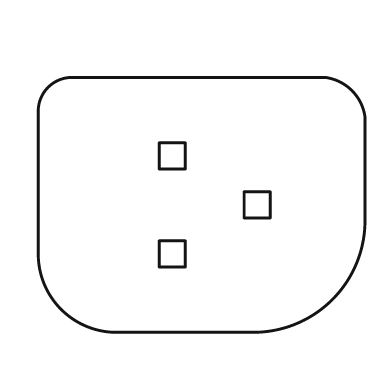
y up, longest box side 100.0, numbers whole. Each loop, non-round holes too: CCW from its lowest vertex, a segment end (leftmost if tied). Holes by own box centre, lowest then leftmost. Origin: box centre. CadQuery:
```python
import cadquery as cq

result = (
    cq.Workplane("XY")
    .moveTo(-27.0, -39.0)
    .lineTo(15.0, -39.0)
    .threePointArc((40.0, -29.0), (50.0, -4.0))
    .lineTo(50.0, 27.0)
    .threePointArc((46.0, 35.0), (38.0, 39.0))
    .lineTo(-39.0, 39.0)
    .threePointArc((-47.0, 36.0), (-50.0, 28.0))
    .lineTo(-50.0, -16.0)
    .threePointArc((-43.0, -32.0), (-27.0, -39.0))
    .close()
    .moveTo(-13.0, -19.0)
    .lineTo(-5.0, -19.0)
    .lineTo(-5.0, -11.0)
    .lineTo(-13.0, -11.0)
    .close()
    .moveTo(13.0, -4.0)
    .lineTo(21.0, -4.0)
    .lineTo(21.0, 4.0)
    .lineTo(13.0, 4.0)
    .close()
    .moveTo(-13.0, 11.0)
    .lineTo(-5.0, 11.0)
    .lineTo(-5.0, 19.0)
    .lineTo(-13.0, 19.0)
    .close()
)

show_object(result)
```